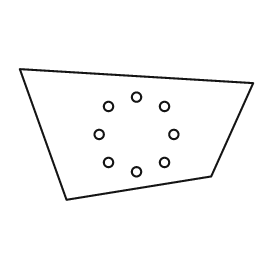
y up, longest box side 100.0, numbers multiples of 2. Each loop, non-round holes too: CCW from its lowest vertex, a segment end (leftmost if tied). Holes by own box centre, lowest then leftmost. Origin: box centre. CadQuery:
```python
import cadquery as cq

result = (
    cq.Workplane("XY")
    .moveTo(-30.0, -28.0)
    .lineTo(32.0, -18.0)
    .lineTo(50.0, 22.0)
    .lineTo(-50.0, 28.0)
    .close()
    .moveTo(0.0, -16.0)
    .circle(2.0)
    .moveTo(-12.0, -12.0)
    .circle(2.0)
    .moveTo(12.0, -12.0)
    .circle(2.0)
    .moveTo(-16.0, 0.0)
    .circle(2.0)
    .moveTo(16.0, 0.0)
    .circle(2.0)
    .moveTo(-12.0, 12.0)
    .circle(2.0)
    .moveTo(12.0, 12.0)
    .circle(2.0)
    .moveTo(0.0, 16.0)
    .circle(2.0)
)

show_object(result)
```